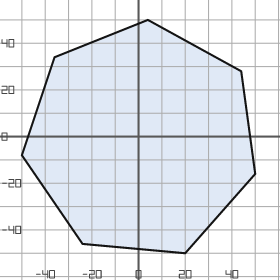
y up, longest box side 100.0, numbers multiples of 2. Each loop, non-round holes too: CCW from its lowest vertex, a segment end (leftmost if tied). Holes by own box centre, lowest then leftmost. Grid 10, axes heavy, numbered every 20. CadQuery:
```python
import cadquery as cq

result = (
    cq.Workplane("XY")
    .moveTo(20.0, -50.0)
    .lineTo(50.0, -16.0)
    .lineTo(44.0, 28.0)
    .lineTo(4.0, 50.0)
    .lineTo(-36.0, 34.0)
    .lineTo(-50.0, -8.0)
    .lineTo(-24.0, -46.0)
    .close()
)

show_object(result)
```